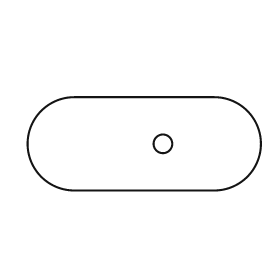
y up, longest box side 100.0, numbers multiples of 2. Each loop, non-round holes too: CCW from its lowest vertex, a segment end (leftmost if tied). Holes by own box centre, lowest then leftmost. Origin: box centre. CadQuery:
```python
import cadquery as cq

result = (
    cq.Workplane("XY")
    .moveTo(-30.0, -20.0)
    .lineTo(30.0, -20.0)
    .threePointArc((50.0, 0.0), (30.0, 20.0))
    .lineTo(-30.0, 20.0)
    .threePointArc((-50.0, 0.0), (-30.0, -20.0))
    .close()
    .moveTo(8.0, 0.0)
    .circle(4.0)
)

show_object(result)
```